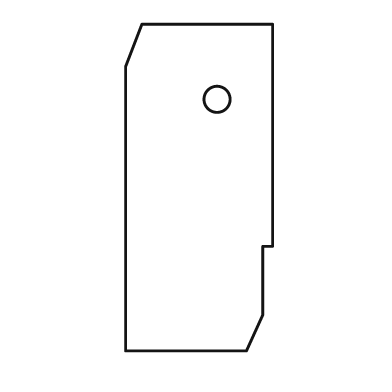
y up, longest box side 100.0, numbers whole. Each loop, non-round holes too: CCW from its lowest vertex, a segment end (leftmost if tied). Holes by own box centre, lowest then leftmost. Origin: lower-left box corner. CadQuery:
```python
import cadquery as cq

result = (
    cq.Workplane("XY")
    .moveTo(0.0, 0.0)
    .lineTo(37.0, 0.0)
    .lineTo(42.0, 11.0)
    .lineTo(42.0, 32.0)
    .lineTo(45.0, 32.0)
    .lineTo(45.0, 100.0)
    .lineTo(5.0, 100.0)
    .lineTo(0.0, 87.0)
    .close()
    .moveTo(28.0, 77.0)
    .circle(4.0)
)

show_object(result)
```